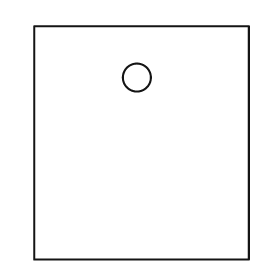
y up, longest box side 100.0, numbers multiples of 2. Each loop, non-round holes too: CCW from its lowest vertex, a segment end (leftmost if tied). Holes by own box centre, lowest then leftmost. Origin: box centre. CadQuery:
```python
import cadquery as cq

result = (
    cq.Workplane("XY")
    .moveTo(-46.0, -50.0)
    .lineTo(46.0, -50.0)
    .lineTo(46.0, 50.0)
    .lineTo(-46.0, 50.0)
    .close()
    .moveTo(-2.0, 28.0)
    .circle(6.0)
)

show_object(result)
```